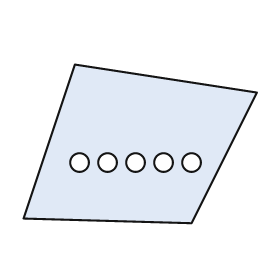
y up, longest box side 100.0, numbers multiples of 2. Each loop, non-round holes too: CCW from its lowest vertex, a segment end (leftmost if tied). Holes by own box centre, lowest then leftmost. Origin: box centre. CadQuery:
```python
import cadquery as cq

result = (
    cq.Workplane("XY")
    .moveTo(22.0, -34.0)
    .lineTo(50.0, 22.0)
    .lineTo(-28.0, 34.0)
    .lineTo(-50.0, -32.0)
    .close()
    .moveTo(-26.0, -8.0)
    .circle(4.0)
    .moveTo(-14.0, -8.0)
    .circle(4.0)
    .moveTo(-2.0, -8.0)
    .circle(4.0)
    .moveTo(10.0, -8.0)
    .circle(4.0)
    .moveTo(22.0, -8.0)
    .circle(4.0)
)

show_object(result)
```